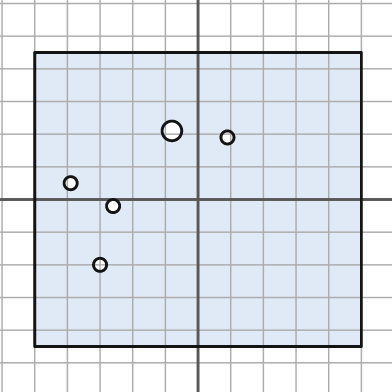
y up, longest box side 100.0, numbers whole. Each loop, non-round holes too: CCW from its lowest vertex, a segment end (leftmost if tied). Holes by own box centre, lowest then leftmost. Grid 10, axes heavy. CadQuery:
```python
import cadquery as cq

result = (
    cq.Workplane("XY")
    .moveTo(-50.0, -45.0)
    .lineTo(50.0, -45.0)
    .lineTo(50.0, 45.0)
    .lineTo(-50.0, 45.0)
    .close()
    .moveTo(-30.0, -20.0)
    .circle(2.0)
    .moveTo(-26.0, -2.0)
    .circle(2.0)
    .moveTo(-39.0, 5.0)
    .circle(2.0)
    .moveTo(9.0, 19.0)
    .circle(2.0)
    .moveTo(-8.0, 21.0)
    .circle(3.0)
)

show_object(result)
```